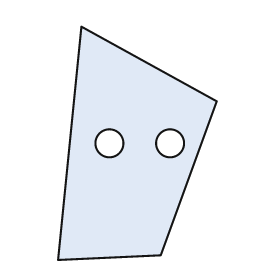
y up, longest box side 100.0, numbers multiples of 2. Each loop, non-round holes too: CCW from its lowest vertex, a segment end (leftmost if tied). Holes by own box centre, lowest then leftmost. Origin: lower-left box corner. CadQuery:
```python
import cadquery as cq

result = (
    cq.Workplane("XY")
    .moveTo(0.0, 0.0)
    .lineTo(44.0, 2.0)
    .lineTo(68.0, 68.0)
    .lineTo(10.0, 100.0)
    .close()
    .moveTo(22.0, 50.0)
    .circle(6.0)
    .moveTo(48.0, 50.0)
    .circle(6.0)
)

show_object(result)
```